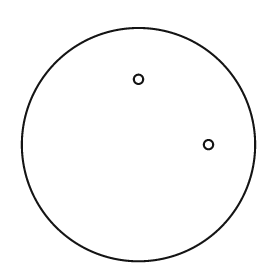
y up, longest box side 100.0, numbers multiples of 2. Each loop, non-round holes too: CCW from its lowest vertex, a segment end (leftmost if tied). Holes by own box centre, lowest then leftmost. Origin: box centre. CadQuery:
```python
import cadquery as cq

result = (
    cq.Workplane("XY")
    .moveTo(0.0, 0.0)
    .circle(50.0)
    .moveTo(30.0, 0.0)
    .circle(2.0)
    .moveTo(0.0, 28.0)
    .circle(2.0)
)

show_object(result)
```